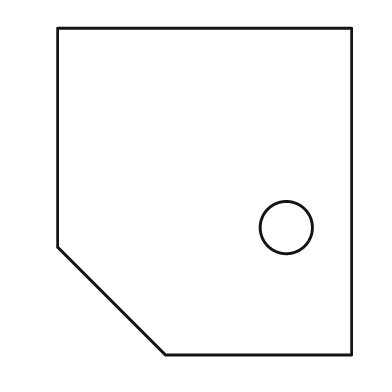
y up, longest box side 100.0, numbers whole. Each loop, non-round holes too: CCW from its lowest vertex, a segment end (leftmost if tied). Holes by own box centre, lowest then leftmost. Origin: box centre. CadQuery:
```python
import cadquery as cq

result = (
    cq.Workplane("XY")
    .moveTo(-12.0, -50.0)
    .lineTo(45.0, -50.0)
    .lineTo(45.0, 50.0)
    .lineTo(-45.0, 50.0)
    .lineTo(-45.0, -17.0)
    .close()
    .moveTo(25.0, -11.0)
    .circle(8.0)
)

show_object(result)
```